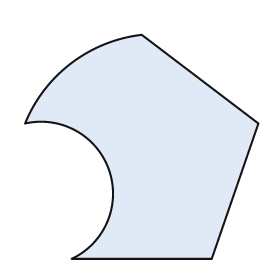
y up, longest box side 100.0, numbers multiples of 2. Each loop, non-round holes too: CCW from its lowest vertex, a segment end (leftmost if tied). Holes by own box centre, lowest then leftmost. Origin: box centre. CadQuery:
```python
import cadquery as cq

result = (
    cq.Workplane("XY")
    .moveTo(-30.0, -48.0)
    .lineTo(30.0, -48.0)
    .lineTo(50.0, 10.0)
    .lineTo(0.0, 48.0)
    .threePointArc((-30.0, 36.0), (-50.0, 10.0))
    .threePointArc((-14.0, -10.0), (-30.0, -48.0))
    .close()
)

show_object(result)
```